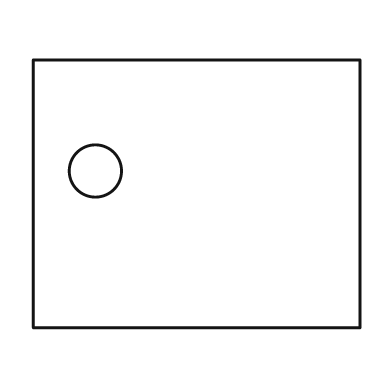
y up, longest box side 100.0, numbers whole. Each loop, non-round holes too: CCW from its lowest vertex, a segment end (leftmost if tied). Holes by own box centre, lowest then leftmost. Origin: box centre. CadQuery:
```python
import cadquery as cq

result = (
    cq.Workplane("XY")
    .moveTo(-50.0, -41.0)
    .lineTo(50.0, -41.0)
    .lineTo(50.0, 41.0)
    .lineTo(-50.0, 41.0)
    .close()
    .moveTo(-31.0, 7.0)
    .circle(8.0)
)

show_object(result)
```